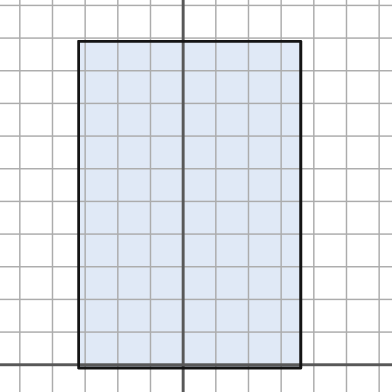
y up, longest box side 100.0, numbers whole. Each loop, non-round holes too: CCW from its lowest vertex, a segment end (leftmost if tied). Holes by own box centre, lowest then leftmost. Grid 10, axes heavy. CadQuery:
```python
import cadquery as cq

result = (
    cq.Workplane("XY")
    .moveTo(-32.0, -1.0)
    .lineTo(36.0, -1.0)
    .lineTo(36.0, 99.0)
    .lineTo(-32.0, 99.0)
    .close()
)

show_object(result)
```